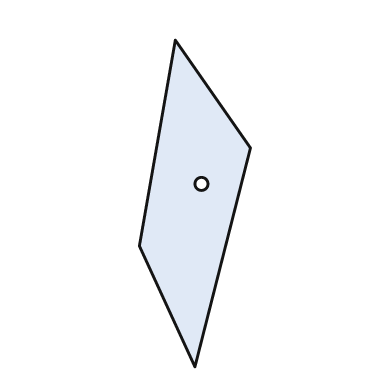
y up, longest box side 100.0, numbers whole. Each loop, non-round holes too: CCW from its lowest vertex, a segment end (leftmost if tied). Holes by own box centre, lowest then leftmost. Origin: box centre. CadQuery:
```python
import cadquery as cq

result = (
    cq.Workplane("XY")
    .moveTo(0.0, -50.0)
    .lineTo(17.0, 17.0)
    .lineTo(-6.0, 50.0)
    .lineTo(-17.0, -13.0)
    .close()
    .moveTo(2.0, 6.0)
    .circle(2.0)
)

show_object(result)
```